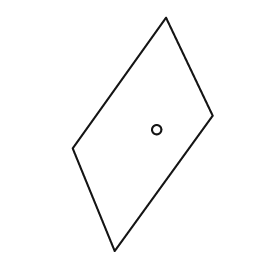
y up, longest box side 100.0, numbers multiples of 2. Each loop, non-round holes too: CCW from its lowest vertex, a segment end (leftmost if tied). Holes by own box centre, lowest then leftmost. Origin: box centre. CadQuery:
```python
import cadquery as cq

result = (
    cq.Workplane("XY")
    .moveTo(-12.0, -50.0)
    .lineTo(30.0, 8.0)
    .lineTo(10.0, 50.0)
    .lineTo(-30.0, -6.0)
    .close()
    .moveTo(6.0, 2.0)
    .circle(2.0)
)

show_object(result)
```